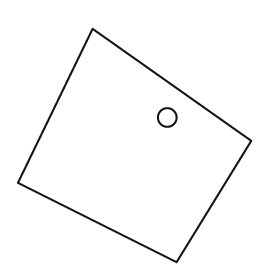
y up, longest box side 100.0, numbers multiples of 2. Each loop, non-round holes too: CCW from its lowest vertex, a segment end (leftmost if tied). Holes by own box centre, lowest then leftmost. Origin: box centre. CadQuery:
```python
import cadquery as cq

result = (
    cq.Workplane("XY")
    .moveTo(18.0, -50.0)
    .lineTo(50.0, 2.0)
    .lineTo(-18.0, 50.0)
    .lineTo(-50.0, -16.0)
    .close()
    .moveTo(14.0, 12.0)
    .circle(4.0)
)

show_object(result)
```